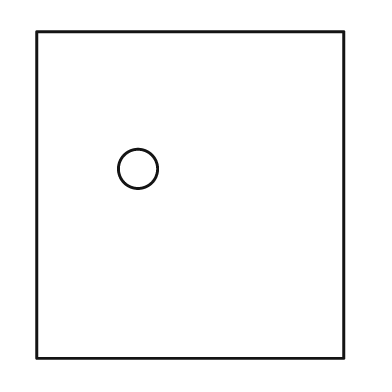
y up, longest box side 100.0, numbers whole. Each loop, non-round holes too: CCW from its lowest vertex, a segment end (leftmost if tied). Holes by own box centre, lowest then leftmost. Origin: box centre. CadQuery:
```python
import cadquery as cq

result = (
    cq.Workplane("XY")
    .moveTo(-47.0, -50.0)
    .lineTo(47.0, -50.0)
    .lineTo(47.0, 50.0)
    .lineTo(-47.0, 50.0)
    .close()
    .moveTo(-16.0, 8.0)
    .circle(6.0)
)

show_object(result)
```